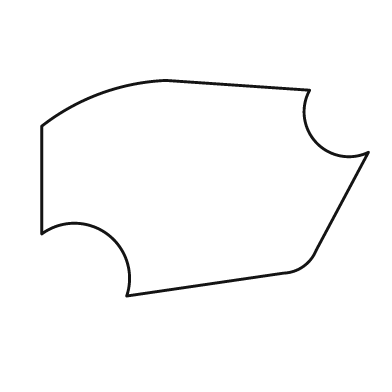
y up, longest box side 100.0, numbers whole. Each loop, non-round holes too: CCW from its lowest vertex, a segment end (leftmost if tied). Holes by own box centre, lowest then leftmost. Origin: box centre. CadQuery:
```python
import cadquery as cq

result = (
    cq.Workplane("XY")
    .moveTo(-24.0, -33.0)
    .lineTo(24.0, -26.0)
    .threePointArc((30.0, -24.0), (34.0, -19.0))
    .lineTo(50.0, 11.0)
    .threePointArc((34.0, 14.0), (32.0, 30.0))
    .lineTo(-12.0, 33.0)
    .threePointArc((-32.0, 29.0), (-50.0, 19.0))
    .lineTo(-50.0, -14.0)
    .threePointArc((-30.0, -14.0), (-24.0, -33.0))
    .close()
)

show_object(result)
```